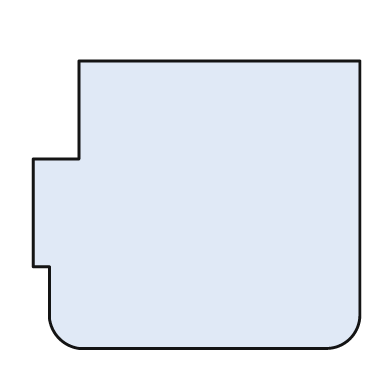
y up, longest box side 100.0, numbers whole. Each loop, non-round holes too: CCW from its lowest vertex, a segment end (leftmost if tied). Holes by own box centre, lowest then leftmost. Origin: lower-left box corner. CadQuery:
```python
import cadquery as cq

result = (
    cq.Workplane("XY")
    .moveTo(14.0, 0.0)
    .lineTo(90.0, 0.0)
    .threePointArc((97.0, 3.0), (100.0, 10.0))
    .lineTo(100.0, 88.0)
    .lineTo(14.0, 88.0)
    .lineTo(14.0, 58.0)
    .lineTo(0.0, 58.0)
    .lineTo(0.0, 25.0)
    .lineTo(5.0, 25.0)
    .lineTo(5.0, 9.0)
    .threePointArc((8.0, 3.0), (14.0, 0.0))
    .close()
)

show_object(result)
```